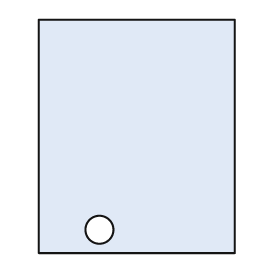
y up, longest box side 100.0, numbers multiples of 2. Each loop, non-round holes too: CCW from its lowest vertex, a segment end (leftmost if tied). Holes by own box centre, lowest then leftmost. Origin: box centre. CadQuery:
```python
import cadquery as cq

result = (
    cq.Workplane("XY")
    .moveTo(-42.0, -50.0)
    .lineTo(42.0, -50.0)
    .lineTo(42.0, 50.0)
    .lineTo(-42.0, 50.0)
    .close()
    .moveTo(-16.0, -40.0)
    .circle(6.0)
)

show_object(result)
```